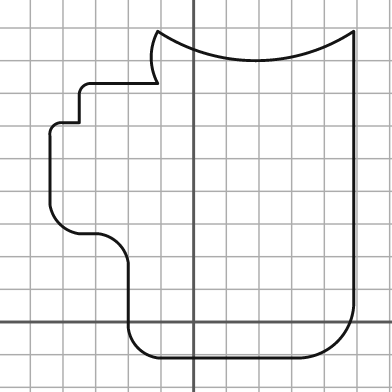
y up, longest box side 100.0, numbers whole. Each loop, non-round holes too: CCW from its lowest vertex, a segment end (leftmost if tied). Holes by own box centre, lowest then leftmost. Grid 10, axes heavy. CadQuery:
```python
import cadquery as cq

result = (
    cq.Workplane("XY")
    .moveTo(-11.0, -11.0)
    .lineTo(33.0, -11.0)
    .threePointArc((44.0, -6.0), (49.0, 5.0))
    .lineTo(49.0, 89.0)
    .threePointArc((19.0, 80.0), (-11.0, 89.0))
    .threePointArc((-13.0, 81.0), (-11.0, 73.0))
    .lineTo(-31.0, 73.0)
    .threePointArc((-34.0, 72.0), (-35.0, 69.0))
    .lineTo(-35.0, 61.0)
    .lineTo(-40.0, 61.0)
    .threePointArc((-43.0, 60.0), (-44.0, 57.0))
    .lineTo(-44.0, 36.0)
    .threePointArc((-41.0, 30.0), (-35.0, 27.0))
    .lineTo(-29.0, 27.0)
    .threePointArc((-23.0, 24.0), (-20.0, 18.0))
    .lineTo(-20.0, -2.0)
    .threePointArc((-17.0, -8.0), (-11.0, -11.0))
    .close()
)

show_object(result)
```